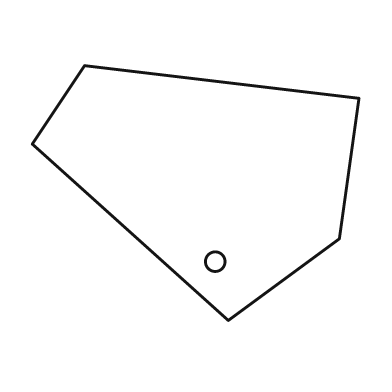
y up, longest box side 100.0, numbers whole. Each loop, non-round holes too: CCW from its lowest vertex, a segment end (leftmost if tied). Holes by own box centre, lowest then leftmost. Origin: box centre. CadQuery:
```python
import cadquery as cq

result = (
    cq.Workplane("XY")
    .moveTo(10.0, -39.0)
    .lineTo(44.0, -14.0)
    .lineTo(50.0, 29.0)
    .lineTo(-34.0, 39.0)
    .lineTo(-50.0, 15.0)
    .close()
    .moveTo(6.0, -21.0)
    .circle(3.0)
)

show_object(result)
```